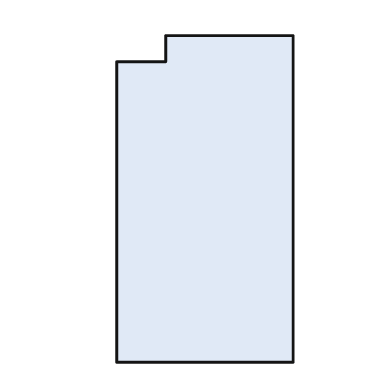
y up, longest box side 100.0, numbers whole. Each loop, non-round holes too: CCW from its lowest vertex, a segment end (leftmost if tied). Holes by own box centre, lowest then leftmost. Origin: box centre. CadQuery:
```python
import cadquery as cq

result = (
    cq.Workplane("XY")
    .moveTo(-27.0, -50.0)
    .lineTo(27.0, -50.0)
    .lineTo(27.0, 50.0)
    .lineTo(-12.0, 50.0)
    .lineTo(-12.0, 42.0)
    .lineTo(-27.0, 42.0)
    .close()
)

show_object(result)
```